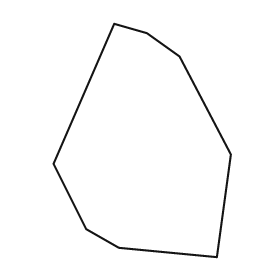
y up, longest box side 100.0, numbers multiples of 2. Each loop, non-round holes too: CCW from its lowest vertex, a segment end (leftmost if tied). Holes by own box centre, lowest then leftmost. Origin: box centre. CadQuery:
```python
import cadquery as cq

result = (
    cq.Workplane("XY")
    .moveTo(32.0, -50.0)
    .lineTo(38.0, -6.0)
    .lineTo(16.0, 36.0)
    .lineTo(2.0, 46.0)
    .lineTo(-12.0, 50.0)
    .lineTo(-38.0, -10.0)
    .lineTo(-24.0, -38.0)
    .lineTo(-10.0, -46.0)
    .close()
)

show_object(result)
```